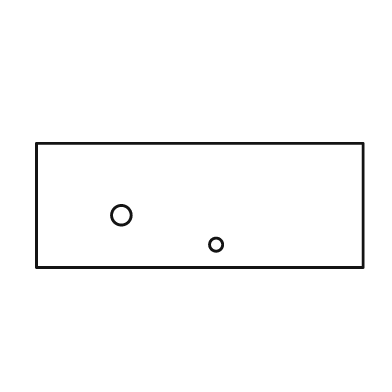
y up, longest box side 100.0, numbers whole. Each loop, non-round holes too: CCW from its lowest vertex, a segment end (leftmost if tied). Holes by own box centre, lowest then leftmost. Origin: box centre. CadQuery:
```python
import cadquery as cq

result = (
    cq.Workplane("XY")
    .moveTo(-50.0, -19.0)
    .lineTo(50.0, -19.0)
    .lineTo(50.0, 19.0)
    .lineTo(-50.0, 19.0)
    .close()
    .moveTo(5.0, -12.0)
    .circle(2.0)
    .moveTo(-24.0, -3.0)
    .circle(3.0)
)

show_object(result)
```